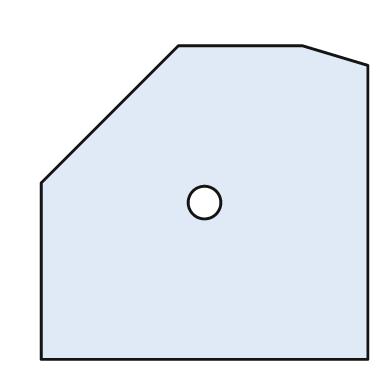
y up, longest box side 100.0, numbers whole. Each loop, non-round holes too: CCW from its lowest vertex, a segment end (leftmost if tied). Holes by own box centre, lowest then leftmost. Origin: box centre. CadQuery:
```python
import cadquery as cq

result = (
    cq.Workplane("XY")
    .moveTo(-50.0, -48.0)
    .lineTo(50.0, -48.0)
    .lineTo(50.0, 42.0)
    .lineTo(30.0, 48.0)
    .lineTo(-8.0, 48.0)
    .lineTo(-50.0, 6.0)
    .close()
    .moveTo(0.0, 0.0)
    .circle(5.0)
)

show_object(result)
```